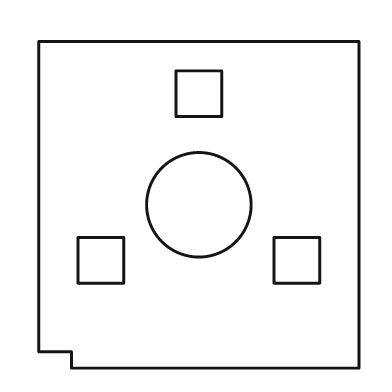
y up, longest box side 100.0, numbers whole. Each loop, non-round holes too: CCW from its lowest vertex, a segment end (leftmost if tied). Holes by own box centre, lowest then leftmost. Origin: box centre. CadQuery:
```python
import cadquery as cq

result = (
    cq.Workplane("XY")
    .moveTo(-39.0, -50.0)
    .lineTo(49.0, -50.0)
    .lineTo(49.0, 50.0)
    .lineTo(-49.0, 50.0)
    .lineTo(-49.0, -45.0)
    .lineTo(-39.0, -45.0)
    .close()
    .moveTo(-37.0, -24.0)
    .lineTo(-23.0, -24.0)
    .lineTo(-23.0, -10.0)
    .lineTo(-37.0, -10.0)
    .close()
    .moveTo(23.0, -24.0)
    .lineTo(37.0, -24.0)
    .lineTo(37.0, -10.0)
    .lineTo(23.0, -10.0)
    .close()
    .moveTo(0.0, 0.0)
    .circle(16.0)
    .moveTo(-7.0, 27.0)
    .lineTo(7.0, 27.0)
    .lineTo(7.0, 41.0)
    .lineTo(-7.0, 41.0)
    .close()
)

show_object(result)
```